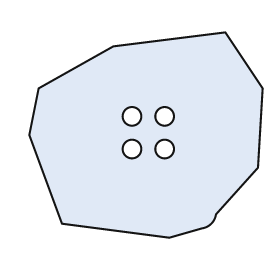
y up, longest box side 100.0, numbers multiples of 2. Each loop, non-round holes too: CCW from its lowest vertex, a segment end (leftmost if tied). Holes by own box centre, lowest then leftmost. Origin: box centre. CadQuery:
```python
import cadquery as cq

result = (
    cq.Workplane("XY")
    .moveTo(10.0, -44.0)
    .lineTo(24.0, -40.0)
    .threePointArc((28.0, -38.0), (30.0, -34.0))
    .lineTo(48.0, -14.0)
    .lineTo(50.0, 20.0)
    .lineTo(34.0, 44.0)
    .lineTo(-14.0, 38.0)
    .lineTo(-46.0, 20.0)
    .lineTo(-50.0, 0.0)
    .lineTo(-36.0, -38.0)
    .close()
    .moveTo(-6.0, -6.0)
    .circle(4.0)
    .moveTo(8.0, -6.0)
    .circle(4.0)
    .moveTo(-6.0, 8.0)
    .circle(4.0)
    .moveTo(8.0, 8.0)
    .circle(4.0)
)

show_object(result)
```